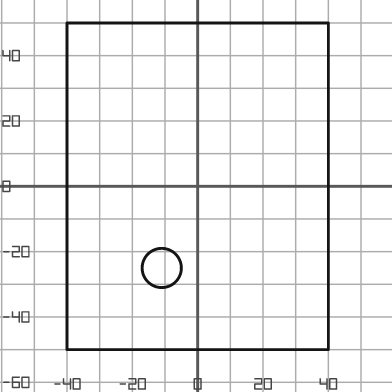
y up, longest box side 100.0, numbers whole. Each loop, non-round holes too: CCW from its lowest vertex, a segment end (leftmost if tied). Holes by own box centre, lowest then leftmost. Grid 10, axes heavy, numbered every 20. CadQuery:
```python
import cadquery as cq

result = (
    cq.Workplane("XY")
    .moveTo(-40.0, -50.0)
    .lineTo(40.0, -50.0)
    .lineTo(40.0, 50.0)
    .lineTo(-40.0, 50.0)
    .close()
    .moveTo(-11.0, -25.0)
    .circle(6.0)
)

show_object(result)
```